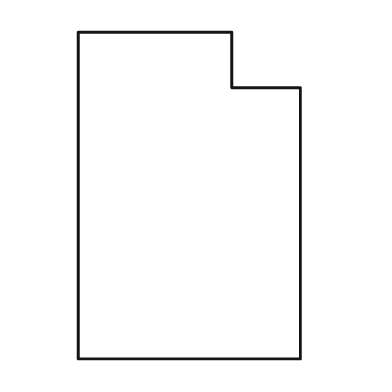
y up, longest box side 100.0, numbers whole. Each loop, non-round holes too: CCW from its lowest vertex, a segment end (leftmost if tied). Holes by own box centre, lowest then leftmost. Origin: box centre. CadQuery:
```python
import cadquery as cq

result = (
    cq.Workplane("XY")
    .moveTo(-34.0, -50.0)
    .lineTo(34.0, -50.0)
    .lineTo(34.0, 33.0)
    .lineTo(13.0, 33.0)
    .lineTo(13.0, 50.0)
    .lineTo(-34.0, 50.0)
    .close()
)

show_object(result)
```